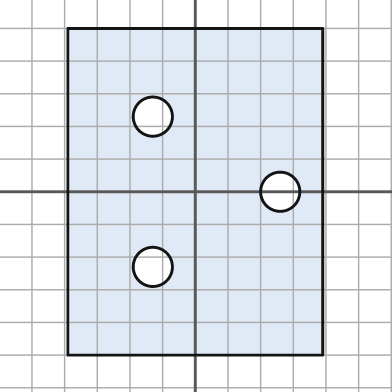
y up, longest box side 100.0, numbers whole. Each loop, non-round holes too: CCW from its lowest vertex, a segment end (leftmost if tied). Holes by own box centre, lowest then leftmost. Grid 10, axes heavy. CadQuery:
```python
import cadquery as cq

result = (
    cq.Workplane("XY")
    .moveTo(-39.0, -50.0)
    .lineTo(39.0, -50.0)
    .lineTo(39.0, 50.0)
    .lineTo(-39.0, 50.0)
    .close()
    .moveTo(-13.0, -23.0)
    .circle(6.0)
    .moveTo(26.0, 0.0)
    .circle(6.0)
    .moveTo(-13.0, 23.0)
    .circle(6.0)
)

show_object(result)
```